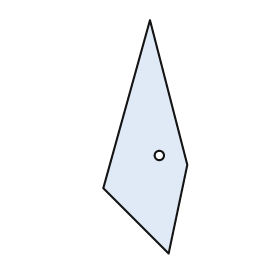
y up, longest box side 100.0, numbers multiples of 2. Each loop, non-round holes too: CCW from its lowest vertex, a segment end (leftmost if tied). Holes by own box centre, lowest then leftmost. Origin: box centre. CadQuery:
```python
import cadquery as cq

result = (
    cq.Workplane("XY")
    .moveTo(10.0, -50.0)
    .lineTo(18.0, -12.0)
    .lineTo(2.0, 50.0)
    .lineTo(-18.0, -22.0)
    .close()
    .moveTo(6.0, -8.0)
    .circle(2.0)
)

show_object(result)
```